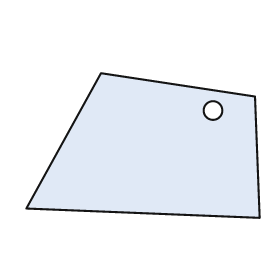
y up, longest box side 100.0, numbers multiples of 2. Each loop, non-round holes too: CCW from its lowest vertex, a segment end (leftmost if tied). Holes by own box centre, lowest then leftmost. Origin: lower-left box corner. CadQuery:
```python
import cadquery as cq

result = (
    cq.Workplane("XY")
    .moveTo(100.0, 0.0)
    .lineTo(98.0, 52.0)
    .lineTo(32.0, 62.0)
    .lineTo(0.0, 4.0)
    .close()
    .moveTo(80.0, 46.0)
    .circle(4.0)
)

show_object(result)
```